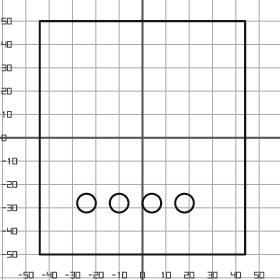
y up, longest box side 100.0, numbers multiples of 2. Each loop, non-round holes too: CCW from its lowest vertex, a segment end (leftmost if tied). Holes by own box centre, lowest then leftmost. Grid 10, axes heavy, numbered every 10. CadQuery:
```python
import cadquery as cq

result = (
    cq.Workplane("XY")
    .moveTo(-44.0, -50.0)
    .lineTo(44.0, -50.0)
    .lineTo(44.0, 50.0)
    .lineTo(-44.0, 50.0)
    .close()
    .moveTo(-24.0, -28.0)
    .circle(4.0)
    .moveTo(-10.0, -28.0)
    .circle(4.0)
    .moveTo(4.0, -28.0)
    .circle(4.0)
    .moveTo(18.0, -28.0)
    .circle(4.0)
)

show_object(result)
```